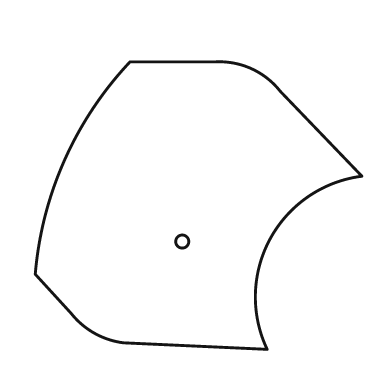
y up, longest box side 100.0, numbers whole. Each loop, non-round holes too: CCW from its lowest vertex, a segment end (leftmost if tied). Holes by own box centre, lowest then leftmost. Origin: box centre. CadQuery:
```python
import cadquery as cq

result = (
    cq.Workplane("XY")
    .moveTo(21.0, -44.0)
    .threePointArc((22.0, -10.0), (50.0, 9.0))
    .lineTo(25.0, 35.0)
    .threePointArc((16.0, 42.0), (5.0, 44.0))
    .lineTo(-21.0, 44.0)
    .threePointArc((-41.0, 14.0), (-50.0, -21.0))
    .lineTo(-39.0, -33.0)
    .threePointArc((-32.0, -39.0), (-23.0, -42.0))
    .close()
    .moveTo(-5.0, -11.0)
    .circle(2.0)
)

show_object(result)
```